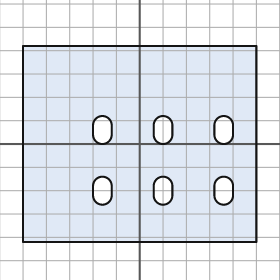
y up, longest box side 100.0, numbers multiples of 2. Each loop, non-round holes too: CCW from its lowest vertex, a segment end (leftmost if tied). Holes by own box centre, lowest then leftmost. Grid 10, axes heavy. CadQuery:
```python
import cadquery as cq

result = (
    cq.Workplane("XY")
    .moveTo(-50.0, -42.0)
    .lineTo(50.0, -42.0)
    .lineTo(50.0, 42.0)
    .lineTo(-50.0, 42.0)
    .close()
    .moveTo(-20.0, -22.0)
    .threePointArc((-16.0, -26.0), (-12.0, -22.0))
    .lineTo(-12.0, -18.0)
    .threePointArc((-16.0, -14.0), (-20.0, -18.0))
    .close()
    .moveTo(6.0, -22.0)
    .threePointArc((10.0, -26.0), (14.0, -22.0))
    .lineTo(14.0, -18.0)
    .threePointArc((10.0, -14.0), (6.0, -18.0))
    .close()
    .moveTo(32.0, -22.0)
    .threePointArc((36.0, -26.0), (40.0, -22.0))
    .lineTo(40.0, -18.0)
    .threePointArc((36.0, -14.0), (32.0, -18.0))
    .close()
    .moveTo(-20.0, 4.0)
    .threePointArc((-16.0, 0.0), (-12.0, 4.0))
    .lineTo(-12.0, 8.0)
    .threePointArc((-16.0, 12.0), (-20.0, 8.0))
    .close()
    .moveTo(6.0, 4.0)
    .threePointArc((10.0, 0.0), (14.0, 4.0))
    .lineTo(14.0, 8.0)
    .threePointArc((10.0, 12.0), (6.0, 8.0))
    .close()
    .moveTo(32.0, 4.0)
    .threePointArc((36.0, 0.0), (40.0, 4.0))
    .lineTo(40.0, 8.0)
    .threePointArc((36.0, 12.0), (32.0, 8.0))
    .close()
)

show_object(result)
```